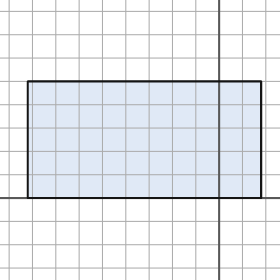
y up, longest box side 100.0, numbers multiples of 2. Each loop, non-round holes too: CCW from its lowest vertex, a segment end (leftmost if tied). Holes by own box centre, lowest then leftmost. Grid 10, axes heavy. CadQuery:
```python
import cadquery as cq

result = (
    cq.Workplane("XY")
    .moveTo(-82.0, 0.0)
    .lineTo(18.0, 0.0)
    .lineTo(18.0, 50.0)
    .lineTo(-82.0, 50.0)
    .close()
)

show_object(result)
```